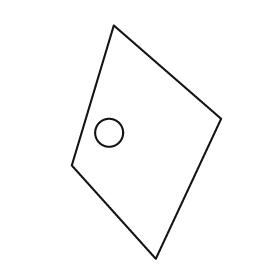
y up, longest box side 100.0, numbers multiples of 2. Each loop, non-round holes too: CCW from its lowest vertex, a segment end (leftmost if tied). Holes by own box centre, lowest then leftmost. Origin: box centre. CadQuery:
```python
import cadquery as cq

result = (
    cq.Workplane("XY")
    .moveTo(4.0, -50.0)
    .lineTo(32.0, 10.0)
    .lineTo(-14.0, 50.0)
    .lineTo(-32.0, -10.0)
    .close()
    .moveTo(-16.0, 4.0)
    .circle(6.0)
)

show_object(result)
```